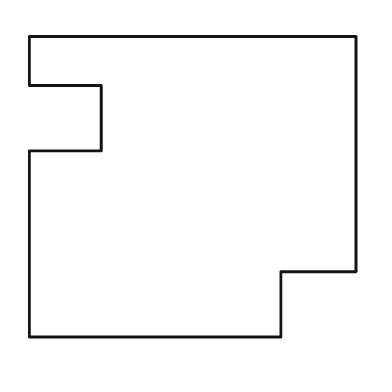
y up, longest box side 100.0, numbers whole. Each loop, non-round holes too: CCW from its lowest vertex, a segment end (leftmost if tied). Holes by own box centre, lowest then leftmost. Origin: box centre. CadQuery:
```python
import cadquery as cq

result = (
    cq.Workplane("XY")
    .moveTo(-50.0, -46.0)
    .lineTo(27.0, -46.0)
    .lineTo(27.0, -26.0)
    .lineTo(50.0, -26.0)
    .lineTo(50.0, 46.0)
    .lineTo(-50.0, 46.0)
    .lineTo(-50.0, 31.0)
    .lineTo(-28.0, 31.0)
    .lineTo(-28.0, 11.0)
    .lineTo(-50.0, 11.0)
    .close()
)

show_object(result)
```